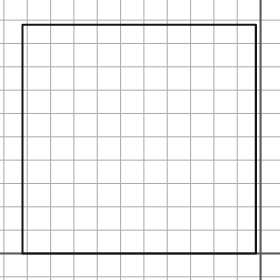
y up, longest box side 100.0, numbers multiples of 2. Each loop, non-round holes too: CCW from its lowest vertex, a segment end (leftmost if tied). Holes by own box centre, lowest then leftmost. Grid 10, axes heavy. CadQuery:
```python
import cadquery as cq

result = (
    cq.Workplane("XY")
    .moveTo(-102.0, 0.0)
    .lineTo(-2.0, 0.0)
    .lineTo(-2.0, 98.0)
    .lineTo(-102.0, 98.0)
    .close()
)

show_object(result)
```